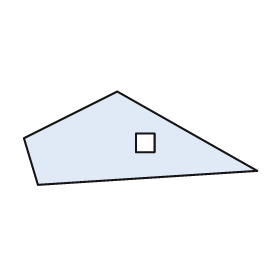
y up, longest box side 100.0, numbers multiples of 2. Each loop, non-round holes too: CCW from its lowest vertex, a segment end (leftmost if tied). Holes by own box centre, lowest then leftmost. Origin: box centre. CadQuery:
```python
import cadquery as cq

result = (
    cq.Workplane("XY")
    .moveTo(-44.0, -20.0)
    .lineTo(50.0, -14.0)
    .lineTo(-10.0, 20.0)
    .lineTo(-50.0, 0.0)
    .close()
    .moveTo(-2.0, -6.0)
    .lineTo(6.0, -6.0)
    .lineTo(6.0, 2.0)
    .lineTo(-2.0, 2.0)
    .close()
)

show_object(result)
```